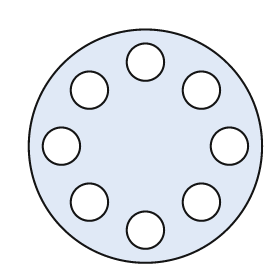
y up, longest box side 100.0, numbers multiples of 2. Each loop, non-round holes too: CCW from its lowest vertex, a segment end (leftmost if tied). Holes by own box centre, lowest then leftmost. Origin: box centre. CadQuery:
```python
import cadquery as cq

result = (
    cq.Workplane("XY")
    .moveTo(0.0, 0.0)
    .circle(50.0)
    .moveTo(0.0, -36.0)
    .circle(8.0)
    .moveTo(-24.0, -24.0)
    .circle(8.0)
    .moveTo(24.0, -24.0)
    .circle(8.0)
    .moveTo(-36.0, 0.0)
    .circle(8.0)
    .moveTo(36.0, 0.0)
    .circle(8.0)
    .moveTo(-24.0, 24.0)
    .circle(8.0)
    .moveTo(24.0, 24.0)
    .circle(8.0)
    .moveTo(0.0, 36.0)
    .circle(8.0)
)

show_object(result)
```